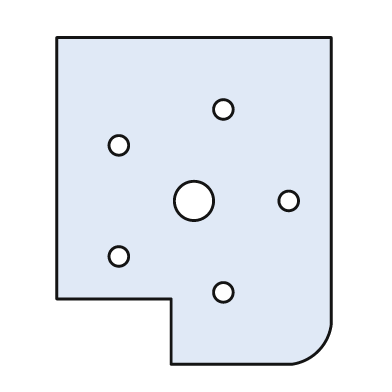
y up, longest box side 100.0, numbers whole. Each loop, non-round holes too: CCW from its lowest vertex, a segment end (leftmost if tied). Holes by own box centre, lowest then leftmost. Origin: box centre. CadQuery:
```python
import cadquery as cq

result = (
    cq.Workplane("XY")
    .moveTo(-7.0, -50.0)
    .lineTo(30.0, -50.0)
    .threePointArc((38.0, -46.0), (42.0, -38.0))
    .lineTo(42.0, 50.0)
    .lineTo(-42.0, 50.0)
    .lineTo(-42.0, -30.0)
    .lineTo(-7.0, -30.0)
    .close()
    .moveTo(9.0, -28.0)
    .circle(3.0)
    .moveTo(-23.0, -17.0)
    .circle(3.0)
    .moveTo(0.0, 0.0)
    .circle(6.0)
    .moveTo(29.0, 0.0)
    .circle(3.0)
    .moveTo(-23.0, 17.0)
    .circle(3.0)
    .moveTo(9.0, 28.0)
    .circle(3.0)
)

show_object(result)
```